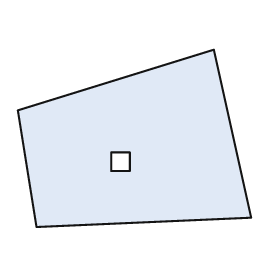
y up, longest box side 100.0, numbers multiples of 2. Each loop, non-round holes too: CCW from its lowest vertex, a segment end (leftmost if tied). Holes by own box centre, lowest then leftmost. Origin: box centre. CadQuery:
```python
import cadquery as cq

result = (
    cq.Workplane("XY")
    .moveTo(-42.0, -38.0)
    .lineTo(50.0, -34.0)
    .lineTo(34.0, 38.0)
    .lineTo(-50.0, 12.0)
    .close()
    .moveTo(-10.0, -14.0)
    .lineTo(-2.0, -14.0)
    .lineTo(-2.0, -6.0)
    .lineTo(-10.0, -6.0)
    .close()
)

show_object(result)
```